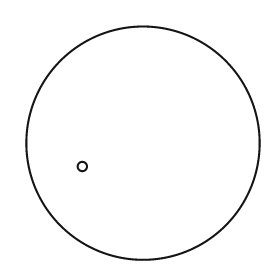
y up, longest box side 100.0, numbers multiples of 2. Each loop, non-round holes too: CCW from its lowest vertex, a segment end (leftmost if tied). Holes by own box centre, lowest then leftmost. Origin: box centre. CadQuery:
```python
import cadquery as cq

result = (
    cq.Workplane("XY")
    .moveTo(0.0, 0.0)
    .circle(50.0)
    .moveTo(-26.0, -10.0)
    .circle(2.0)
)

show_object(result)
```